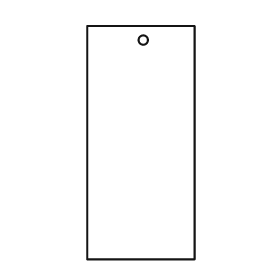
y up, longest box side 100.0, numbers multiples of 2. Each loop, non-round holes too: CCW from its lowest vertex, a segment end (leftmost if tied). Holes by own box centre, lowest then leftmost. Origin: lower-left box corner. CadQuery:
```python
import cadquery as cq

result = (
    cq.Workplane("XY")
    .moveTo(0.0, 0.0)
    .lineTo(46.0, 0.0)
    .lineTo(46.0, 100.0)
    .lineTo(0.0, 100.0)
    .close()
    .moveTo(24.0, 94.0)
    .circle(2.0)
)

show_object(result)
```